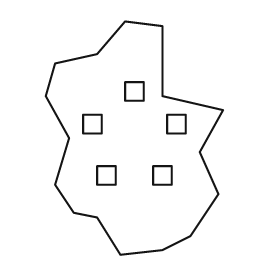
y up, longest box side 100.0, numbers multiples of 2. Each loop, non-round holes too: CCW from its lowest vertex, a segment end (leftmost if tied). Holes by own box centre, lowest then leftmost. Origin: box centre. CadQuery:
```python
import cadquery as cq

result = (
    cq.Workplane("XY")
    .moveTo(-6.0, -50.0)
    .lineTo(12.0, -48.0)
    .lineTo(24.0, -42.0)
    .lineTo(36.0, -24.0)
    .lineTo(28.0, -6.0)
    .lineTo(38.0, 12.0)
    .lineTo(12.0, 18.0)
    .lineTo(12.0, 48.0)
    .lineTo(-4.0, 50.0)
    .lineTo(-16.0, 36.0)
    .lineTo(-34.0, 32.0)
    .lineTo(-38.0, 18.0)
    .lineTo(-28.0, 0.0)
    .lineTo(-34.0, -20.0)
    .lineTo(-26.0, -32.0)
    .lineTo(-16.0, -34.0)
    .close()
    .moveTo(-16.0, -20.0)
    .lineTo(-8.0, -20.0)
    .lineTo(-8.0, -12.0)
    .lineTo(-16.0, -12.0)
    .close()
    .moveTo(8.0, -20.0)
    .lineTo(16.0, -20.0)
    .lineTo(16.0, -12.0)
    .lineTo(8.0, -12.0)
    .close()
    .moveTo(-22.0, 2.0)
    .lineTo(-14.0, 2.0)
    .lineTo(-14.0, 10.0)
    .lineTo(-22.0, 10.0)
    .close()
    .moveTo(14.0, 2.0)
    .lineTo(22.0, 2.0)
    .lineTo(22.0, 10.0)
    .lineTo(14.0, 10.0)
    .close()
    .moveTo(-4.0, 16.0)
    .lineTo(4.0, 16.0)
    .lineTo(4.0, 24.0)
    .lineTo(-4.0, 24.0)
    .close()
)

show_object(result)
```